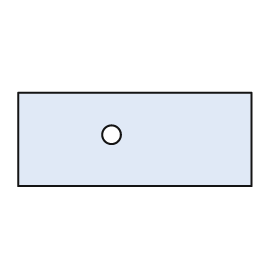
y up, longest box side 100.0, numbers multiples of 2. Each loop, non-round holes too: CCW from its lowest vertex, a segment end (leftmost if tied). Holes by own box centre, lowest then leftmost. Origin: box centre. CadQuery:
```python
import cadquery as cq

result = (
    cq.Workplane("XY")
    .moveTo(-50.0, -20.0)
    .lineTo(50.0, -20.0)
    .lineTo(50.0, 20.0)
    .lineTo(-50.0, 20.0)
    .close()
    .moveTo(-10.0, 2.0)
    .circle(4.0)
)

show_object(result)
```